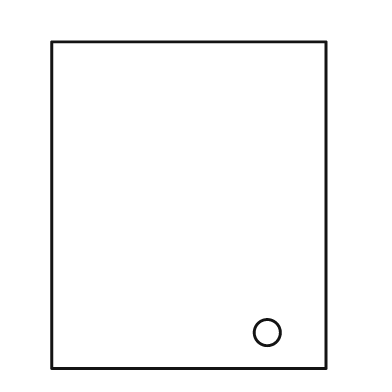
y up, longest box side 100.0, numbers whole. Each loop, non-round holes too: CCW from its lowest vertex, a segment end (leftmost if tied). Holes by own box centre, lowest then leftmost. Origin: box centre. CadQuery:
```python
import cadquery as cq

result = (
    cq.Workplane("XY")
    .moveTo(-42.0, -50.0)
    .lineTo(42.0, -50.0)
    .lineTo(42.0, 50.0)
    .lineTo(-42.0, 50.0)
    .close()
    .moveTo(24.0, -39.0)
    .circle(4.0)
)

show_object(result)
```